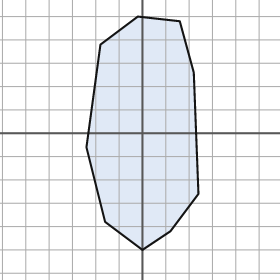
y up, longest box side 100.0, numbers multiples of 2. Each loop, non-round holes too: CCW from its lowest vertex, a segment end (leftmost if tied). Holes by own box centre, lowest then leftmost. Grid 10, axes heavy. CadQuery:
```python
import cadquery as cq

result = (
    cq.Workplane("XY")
    .moveTo(0.0, -50.0)
    .lineTo(12.0, -42.0)
    .lineTo(24.0, -26.0)
    .lineTo(22.0, 26.0)
    .lineTo(16.0, 48.0)
    .lineTo(-2.0, 50.0)
    .lineTo(-18.0, 38.0)
    .lineTo(-24.0, -6.0)
    .lineTo(-16.0, -38.0)
    .close()
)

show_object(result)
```